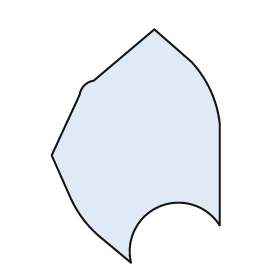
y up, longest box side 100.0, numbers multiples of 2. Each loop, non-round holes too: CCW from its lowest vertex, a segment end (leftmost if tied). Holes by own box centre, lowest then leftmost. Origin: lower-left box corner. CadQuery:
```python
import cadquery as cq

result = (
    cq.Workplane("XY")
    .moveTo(34.0, 0.0)
    .threePointArc((46.0, 24.0), (72.0, 16.0))
    .lineTo(72.0, 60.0)
    .threePointArc((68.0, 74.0), (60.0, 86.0))
    .lineTo(44.0, 100.0)
    .lineTo(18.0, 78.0)
    .threePointArc((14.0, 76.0), (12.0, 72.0))
    .lineTo(0.0, 46.0)
    .lineTo(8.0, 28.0)
    .threePointArc((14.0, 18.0), (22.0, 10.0))
    .close()
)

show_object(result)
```